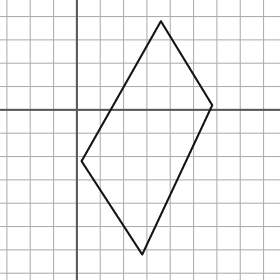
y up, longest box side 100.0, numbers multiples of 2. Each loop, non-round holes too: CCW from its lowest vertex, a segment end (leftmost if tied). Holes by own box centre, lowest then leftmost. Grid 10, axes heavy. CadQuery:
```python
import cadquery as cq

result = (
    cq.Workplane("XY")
    .moveTo(28.0, -62.0)
    .lineTo(58.0, 2.0)
    .lineTo(36.0, 38.0)
    .lineTo(2.0, -22.0)
    .close()
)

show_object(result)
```